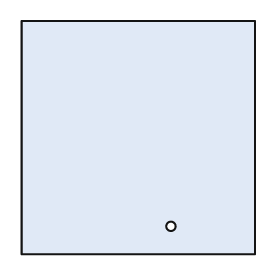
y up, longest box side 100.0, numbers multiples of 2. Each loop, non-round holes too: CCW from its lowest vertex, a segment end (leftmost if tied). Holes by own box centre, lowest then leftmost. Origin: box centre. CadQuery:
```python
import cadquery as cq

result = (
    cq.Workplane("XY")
    .moveTo(-50.0, -50.0)
    .lineTo(50.0, -50.0)
    .lineTo(50.0, 50.0)
    .lineTo(-50.0, 50.0)
    .close()
    .moveTo(14.0, -38.0)
    .circle(2.0)
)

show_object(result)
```